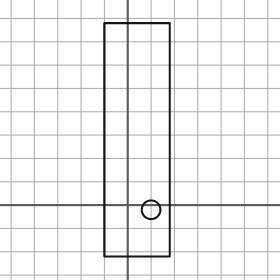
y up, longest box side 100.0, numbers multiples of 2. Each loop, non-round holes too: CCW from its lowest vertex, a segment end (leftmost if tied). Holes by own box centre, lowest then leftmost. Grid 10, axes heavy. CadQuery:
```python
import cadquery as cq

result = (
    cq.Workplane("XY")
    .moveTo(-10.0, -22.0)
    .lineTo(18.0, -22.0)
    .lineTo(18.0, 78.0)
    .lineTo(-10.0, 78.0)
    .close()
    .moveTo(10.0, -2.0)
    .circle(4.0)
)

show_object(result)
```